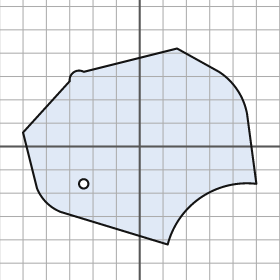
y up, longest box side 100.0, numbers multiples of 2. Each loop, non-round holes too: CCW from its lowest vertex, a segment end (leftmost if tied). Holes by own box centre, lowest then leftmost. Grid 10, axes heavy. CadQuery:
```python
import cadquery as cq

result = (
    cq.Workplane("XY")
    .moveTo(12.0, -42.0)
    .threePointArc((26.0, -22.0), (50.0, -16.0))
    .lineTo(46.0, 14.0)
    .threePointArc((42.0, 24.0), (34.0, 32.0))
    .lineTo(16.0, 42.0)
    .lineTo(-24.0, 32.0)
    .threePointArc((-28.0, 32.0), (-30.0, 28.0))
    .lineTo(-50.0, 6.0)
    .lineTo(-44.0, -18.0)
    .threePointArc((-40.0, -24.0), (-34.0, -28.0))
    .close()
    .moveTo(-24.0, -16.0)
    .circle(2.0)
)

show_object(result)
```